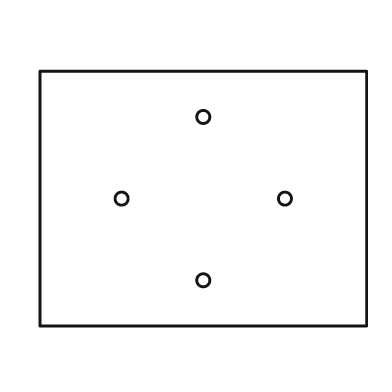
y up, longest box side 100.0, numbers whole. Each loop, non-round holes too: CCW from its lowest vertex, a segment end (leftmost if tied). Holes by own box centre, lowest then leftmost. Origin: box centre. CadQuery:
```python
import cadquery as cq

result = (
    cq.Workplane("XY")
    .moveTo(-50.0, -39.0)
    .lineTo(50.0, -39.0)
    .lineTo(50.0, 39.0)
    .lineTo(-50.0, 39.0)
    .close()
    .moveTo(0.0, -25.0)
    .circle(2.0)
    .moveTo(-25.0, 0.0)
    .circle(2.0)
    .moveTo(25.0, 0.0)
    .circle(2.0)
    .moveTo(0.0, 25.0)
    .circle(2.0)
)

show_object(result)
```